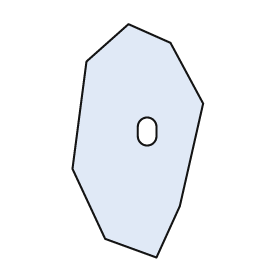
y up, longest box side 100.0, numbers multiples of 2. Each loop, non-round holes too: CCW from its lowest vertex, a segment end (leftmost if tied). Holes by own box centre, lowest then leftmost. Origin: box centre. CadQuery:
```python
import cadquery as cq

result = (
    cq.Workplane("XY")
    .moveTo(8.0, -50.0)
    .lineTo(18.0, -28.0)
    .lineTo(28.0, 16.0)
    .lineTo(14.0, 42.0)
    .lineTo(-4.0, 50.0)
    .lineTo(-22.0, 34.0)
    .lineTo(-28.0, -12.0)
    .lineTo(-14.0, -42.0)
    .close()
    .moveTo(0.0, 2.0)
    .threePointArc((4.0, -2.0), (8.0, 2.0))
    .lineTo(8.0, 6.0)
    .threePointArc((4.0, 10.0), (0.0, 6.0))
    .close()
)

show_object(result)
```